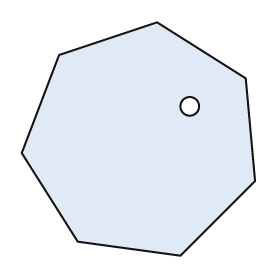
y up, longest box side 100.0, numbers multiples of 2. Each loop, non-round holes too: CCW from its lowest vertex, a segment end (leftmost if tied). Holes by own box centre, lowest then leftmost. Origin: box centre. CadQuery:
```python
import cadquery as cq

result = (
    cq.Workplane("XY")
    .moveTo(18.0, -50.0)
    .lineTo(50.0, -18.0)
    .lineTo(46.0, 26.0)
    .lineTo(8.0, 50.0)
    .lineTo(-34.0, 36.0)
    .lineTo(-50.0, -6.0)
    .lineTo(-26.0, -44.0)
    .close()
    .moveTo(22.0, 14.0)
    .circle(4.0)
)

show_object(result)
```